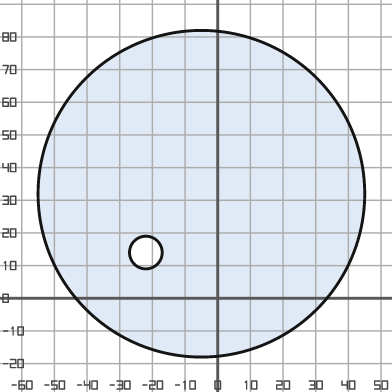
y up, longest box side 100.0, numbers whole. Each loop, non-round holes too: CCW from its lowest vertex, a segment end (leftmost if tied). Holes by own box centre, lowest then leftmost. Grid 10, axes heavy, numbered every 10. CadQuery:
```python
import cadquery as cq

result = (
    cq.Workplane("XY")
    .moveTo(-5.0, 32.0)
    .circle(50.0)
    .moveTo(-22.0, 14.0)
    .circle(5.0)
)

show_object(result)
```